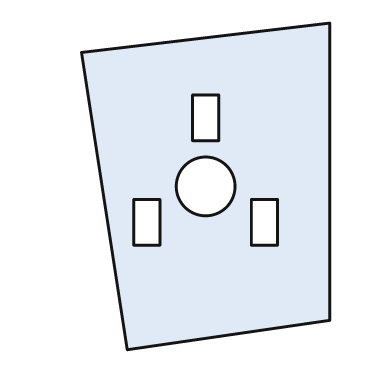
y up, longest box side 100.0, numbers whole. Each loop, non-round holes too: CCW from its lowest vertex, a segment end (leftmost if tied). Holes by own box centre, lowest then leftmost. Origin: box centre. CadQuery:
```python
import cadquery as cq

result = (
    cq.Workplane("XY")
    .moveTo(-24.0, -50.0)
    .lineTo(38.0, -41.0)
    .lineTo(38.0, 50.0)
    .lineTo(-38.0, 41.0)
    .close()
    .moveTo(-22.0, -18.0)
    .lineTo(-14.0, -18.0)
    .lineTo(-14.0, -4.0)
    .lineTo(-22.0, -4.0)
    .close()
    .moveTo(14.0, -18.0)
    .lineTo(22.0, -18.0)
    .lineTo(22.0, -4.0)
    .lineTo(14.0, -4.0)
    .close()
    .moveTo(0.0, 0.0)
    .circle(9.0)
    .moveTo(-4.0, 14.0)
    .lineTo(4.0, 14.0)
    .lineTo(4.0, 28.0)
    .lineTo(-4.0, 28.0)
    .close()
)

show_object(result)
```